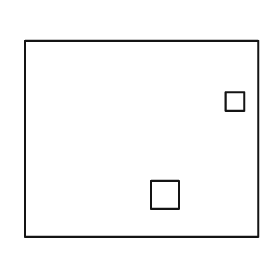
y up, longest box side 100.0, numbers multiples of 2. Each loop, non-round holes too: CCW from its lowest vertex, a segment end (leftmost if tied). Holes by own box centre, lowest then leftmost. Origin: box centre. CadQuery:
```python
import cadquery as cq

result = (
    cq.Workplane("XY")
    .moveTo(-50.0, -42.0)
    .lineTo(50.0, -42.0)
    .lineTo(50.0, 42.0)
    .lineTo(-50.0, 42.0)
    .close()
    .moveTo(4.0, -30.0)
    .lineTo(16.0, -30.0)
    .lineTo(16.0, -18.0)
    .lineTo(4.0, -18.0)
    .close()
    .moveTo(36.0, 12.0)
    .lineTo(44.0, 12.0)
    .lineTo(44.0, 20.0)
    .lineTo(36.0, 20.0)
    .close()
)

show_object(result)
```